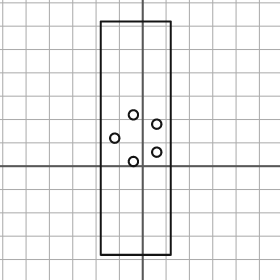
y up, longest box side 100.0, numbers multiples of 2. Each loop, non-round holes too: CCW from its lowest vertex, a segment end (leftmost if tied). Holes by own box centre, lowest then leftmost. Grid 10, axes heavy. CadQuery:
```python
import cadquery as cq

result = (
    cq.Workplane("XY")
    .moveTo(-18.0, -38.0)
    .lineTo(12.0, -38.0)
    .lineTo(12.0, 62.0)
    .lineTo(-18.0, 62.0)
    .close()
    .moveTo(-4.0, 2.0)
    .circle(2.0)
    .moveTo(6.0, 6.0)
    .circle(2.0)
    .moveTo(-12.0, 12.0)
    .circle(2.0)
    .moveTo(6.0, 18.0)
    .circle(2.0)
    .moveTo(-4.0, 22.0)
    .circle(2.0)
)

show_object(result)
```